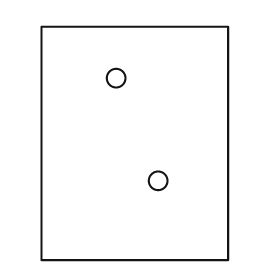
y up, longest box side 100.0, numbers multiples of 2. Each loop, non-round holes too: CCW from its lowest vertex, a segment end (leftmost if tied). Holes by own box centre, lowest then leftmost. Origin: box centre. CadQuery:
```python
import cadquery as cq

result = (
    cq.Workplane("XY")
    .moveTo(-40.0, -50.0)
    .lineTo(40.0, -50.0)
    .lineTo(40.0, 50.0)
    .lineTo(-40.0, 50.0)
    .close()
    .moveTo(10.0, -16.0)
    .circle(4.0)
    .moveTo(-8.0, 28.0)
    .circle(4.0)
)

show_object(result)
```